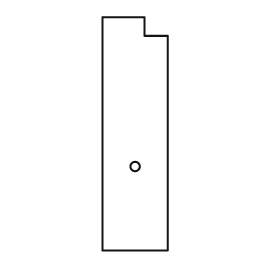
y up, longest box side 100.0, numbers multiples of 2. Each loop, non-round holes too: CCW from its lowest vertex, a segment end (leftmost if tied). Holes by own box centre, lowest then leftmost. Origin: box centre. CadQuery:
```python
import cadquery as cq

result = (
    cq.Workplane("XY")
    .moveTo(-14.0, -50.0)
    .lineTo(14.0, -50.0)
    .lineTo(14.0, 42.0)
    .lineTo(4.0, 42.0)
    .lineTo(4.0, 50.0)
    .lineTo(-14.0, 50.0)
    .close()
    .moveTo(0.0, -14.0)
    .circle(2.0)
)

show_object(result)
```